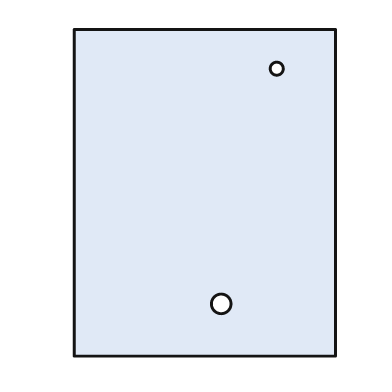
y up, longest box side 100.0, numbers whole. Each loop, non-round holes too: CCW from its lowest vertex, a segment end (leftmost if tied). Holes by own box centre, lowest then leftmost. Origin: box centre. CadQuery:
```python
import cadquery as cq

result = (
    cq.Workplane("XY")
    .moveTo(-40.0, -50.0)
    .lineTo(40.0, -50.0)
    .lineTo(40.0, 50.0)
    .lineTo(-40.0, 50.0)
    .close()
    .moveTo(5.0, -34.0)
    .circle(3.0)
    .moveTo(22.0, 38.0)
    .circle(2.0)
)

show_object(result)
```